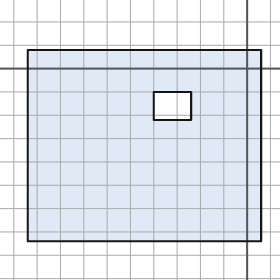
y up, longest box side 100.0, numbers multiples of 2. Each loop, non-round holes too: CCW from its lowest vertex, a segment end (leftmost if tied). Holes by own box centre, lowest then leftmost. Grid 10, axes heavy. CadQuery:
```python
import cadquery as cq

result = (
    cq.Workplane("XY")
    .moveTo(-94.0, -74.0)
    .lineTo(6.0, -74.0)
    .lineTo(6.0, 8.0)
    .lineTo(-94.0, 8.0)
    .close()
    .moveTo(-40.0, -22.0)
    .lineTo(-24.0, -22.0)
    .lineTo(-24.0, -10.0)
    .lineTo(-40.0, -10.0)
    .close()
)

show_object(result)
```